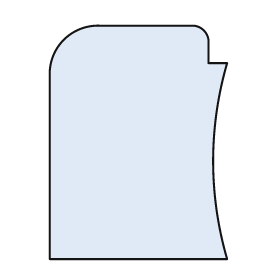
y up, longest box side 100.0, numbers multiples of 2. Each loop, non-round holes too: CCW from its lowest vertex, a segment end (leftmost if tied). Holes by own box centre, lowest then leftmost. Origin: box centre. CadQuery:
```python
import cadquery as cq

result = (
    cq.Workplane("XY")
    .moveTo(-38.0, -50.0)
    .lineTo(38.0, -50.0)
    .threePointArc((32.0, -8.0), (38.0, 34.0))
    .lineTo(30.0, 34.0)
    .lineTo(30.0, 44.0)
    .threePointArc((28.0, 48.0), (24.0, 50.0))
    .lineTo(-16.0, 50.0)
    .threePointArc((-32.0, 44.0), (-38.0, 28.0))
    .close()
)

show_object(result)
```